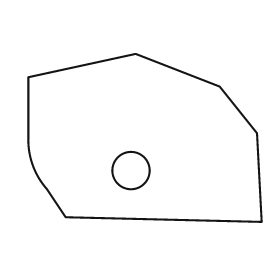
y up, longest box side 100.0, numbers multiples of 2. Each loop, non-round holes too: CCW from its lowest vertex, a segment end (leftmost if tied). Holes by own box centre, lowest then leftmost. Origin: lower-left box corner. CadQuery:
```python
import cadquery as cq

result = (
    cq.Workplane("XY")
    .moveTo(100.0, 0.0)
    .lineTo(98.0, 38.0)
    .lineTo(82.0, 58.0)
    .lineTo(46.0, 72.0)
    .lineTo(0.0, 62.0)
    .lineTo(0.0, 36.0)
    .threePointArc((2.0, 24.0), (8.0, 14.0))
    .lineTo(16.0, 2.0)
    .close()
    .moveTo(44.0, 22.0)
    .circle(8.0)
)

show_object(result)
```